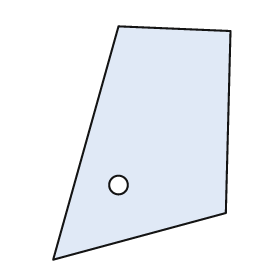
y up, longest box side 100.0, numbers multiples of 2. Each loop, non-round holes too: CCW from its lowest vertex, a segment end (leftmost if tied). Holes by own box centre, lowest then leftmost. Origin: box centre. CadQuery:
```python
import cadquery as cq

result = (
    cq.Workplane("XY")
    .moveTo(-38.0, -50.0)
    .lineTo(36.0, -30.0)
    .lineTo(38.0, 48.0)
    .lineTo(-10.0, 50.0)
    .close()
    .moveTo(-10.0, -18.0)
    .circle(4.0)
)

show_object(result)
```